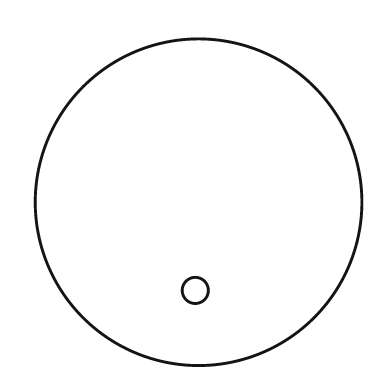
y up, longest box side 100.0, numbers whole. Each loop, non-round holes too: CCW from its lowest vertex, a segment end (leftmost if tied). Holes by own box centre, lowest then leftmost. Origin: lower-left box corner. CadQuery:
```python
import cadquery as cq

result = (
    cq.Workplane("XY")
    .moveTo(50.0, 50.0)
    .circle(50.0)
    .moveTo(49.0, 23.0)
    .circle(4.0)
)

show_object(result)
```